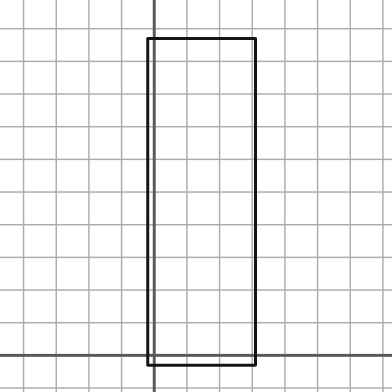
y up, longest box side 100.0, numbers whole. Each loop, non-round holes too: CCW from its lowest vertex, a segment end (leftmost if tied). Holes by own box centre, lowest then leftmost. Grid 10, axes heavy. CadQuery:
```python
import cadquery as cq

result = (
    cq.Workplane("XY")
    .moveTo(-2.0, -3.0)
    .lineTo(31.0, -3.0)
    .lineTo(31.0, 97.0)
    .lineTo(-2.0, 97.0)
    .close()
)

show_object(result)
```